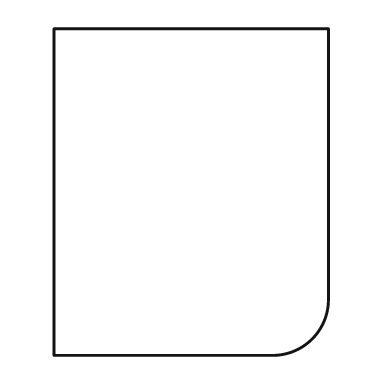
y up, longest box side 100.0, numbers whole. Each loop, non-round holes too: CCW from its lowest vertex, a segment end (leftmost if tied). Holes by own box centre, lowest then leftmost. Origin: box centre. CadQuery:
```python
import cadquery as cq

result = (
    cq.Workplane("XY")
    .moveTo(-42.0, -50.0)
    .lineTo(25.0, -50.0)
    .threePointArc((37.0, -45.0), (42.0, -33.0))
    .lineTo(42.0, 50.0)
    .lineTo(-42.0, 50.0)
    .close()
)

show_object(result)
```